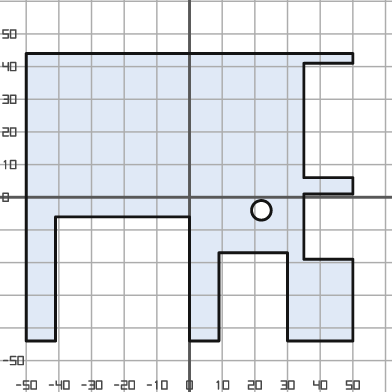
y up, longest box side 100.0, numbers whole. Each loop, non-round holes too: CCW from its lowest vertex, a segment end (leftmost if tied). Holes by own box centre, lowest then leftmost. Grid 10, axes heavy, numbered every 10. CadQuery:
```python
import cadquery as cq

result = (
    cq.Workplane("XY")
    .moveTo(-50.0, -44.0)
    .lineTo(-41.0, -44.0)
    .lineTo(-41.0, -6.0)
    .lineTo(0.0, -6.0)
    .lineTo(0.0, -44.0)
    .lineTo(9.0, -44.0)
    .lineTo(9.0, -17.0)
    .lineTo(30.0, -17.0)
    .lineTo(30.0, -44.0)
    .lineTo(50.0, -44.0)
    .lineTo(50.0, -19.0)
    .lineTo(35.0, -19.0)
    .lineTo(35.0, 1.0)
    .lineTo(50.0, 1.0)
    .lineTo(50.0, 6.0)
    .lineTo(35.0, 6.0)
    .lineTo(35.0, 41.0)
    .lineTo(50.0, 41.0)
    .lineTo(50.0, 44.0)
    .lineTo(-50.0, 44.0)
    .close()
    .moveTo(22.0, -4.0)
    .circle(3.0)
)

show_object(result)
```